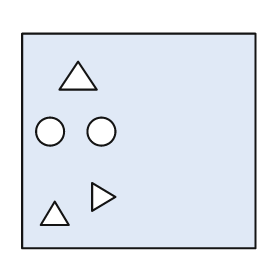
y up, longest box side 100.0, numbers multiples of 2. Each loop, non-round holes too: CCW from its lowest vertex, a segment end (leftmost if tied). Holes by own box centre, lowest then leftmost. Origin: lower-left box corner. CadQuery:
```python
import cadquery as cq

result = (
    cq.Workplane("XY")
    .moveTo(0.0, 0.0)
    .lineTo(100.0, 0.0)
    .lineTo(100.0, 92.0)
    .lineTo(0.0, 92.0)
    .close()
    .moveTo(8.0, 10.0)
    .lineTo(20.0, 10.0)
    .lineTo(14.0, 20.0)
    .close()
    .moveTo(30.0, 16.0)
    .lineTo(40.0, 22.0)
    .lineTo(30.0, 28.0)
    .close()
    .moveTo(12.0, 50.0)
    .circle(6.0)
    .moveTo(34.0, 50.0)
    .circle(6.0)
    .moveTo(16.0, 68.0)
    .lineTo(32.0, 68.0)
    .lineTo(24.0, 80.0)
    .close()
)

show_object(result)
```